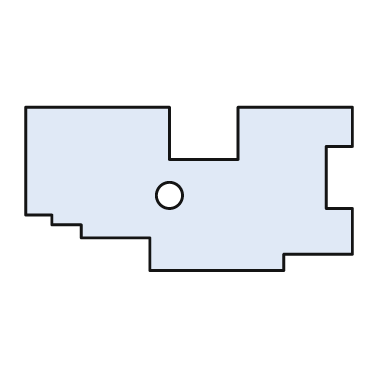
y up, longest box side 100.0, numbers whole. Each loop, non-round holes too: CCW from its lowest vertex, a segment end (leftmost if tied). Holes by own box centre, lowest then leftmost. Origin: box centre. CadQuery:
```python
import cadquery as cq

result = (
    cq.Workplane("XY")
    .moveTo(-12.0, -25.0)
    .lineTo(29.0, -25.0)
    .lineTo(29.0, -20.0)
    .lineTo(50.0, -20.0)
    .lineTo(50.0, -6.0)
    .lineTo(42.0, -6.0)
    .lineTo(42.0, 13.0)
    .lineTo(50.0, 13.0)
    .lineTo(50.0, 25.0)
    .lineTo(15.0, 25.0)
    .lineTo(15.0, 9.0)
    .lineTo(-6.0, 9.0)
    .lineTo(-6.0, 25.0)
    .lineTo(-50.0, 25.0)
    .lineTo(-50.0, -8.0)
    .lineTo(-42.0, -8.0)
    .lineTo(-42.0, -11.0)
    .lineTo(-33.0, -11.0)
    .lineTo(-33.0, -15.0)
    .lineTo(-12.0, -15.0)
    .close()
    .moveTo(-6.0, -2.0)
    .circle(4.0)
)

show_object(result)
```